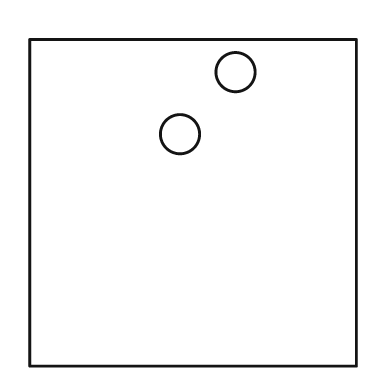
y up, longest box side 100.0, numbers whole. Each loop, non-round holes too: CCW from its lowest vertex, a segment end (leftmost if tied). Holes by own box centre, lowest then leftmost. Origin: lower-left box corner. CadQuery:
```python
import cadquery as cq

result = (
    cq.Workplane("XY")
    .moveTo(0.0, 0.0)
    .lineTo(100.0, 0.0)
    .lineTo(100.0, 100.0)
    .lineTo(0.0, 100.0)
    .close()
    .moveTo(46.0, 71.0)
    .circle(6.0)
    .moveTo(63.0, 90.0)
    .circle(6.0)
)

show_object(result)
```